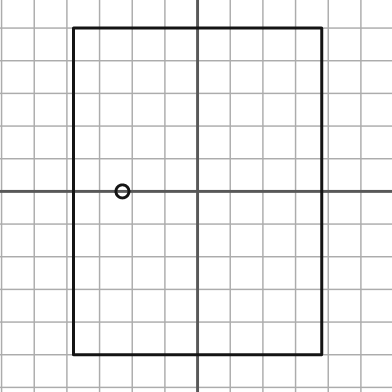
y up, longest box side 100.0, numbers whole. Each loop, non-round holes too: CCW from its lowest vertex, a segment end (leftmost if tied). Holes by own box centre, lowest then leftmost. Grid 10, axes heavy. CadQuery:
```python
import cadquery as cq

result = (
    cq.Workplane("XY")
    .moveTo(-38.0, -50.0)
    .lineTo(38.0, -50.0)
    .lineTo(38.0, 50.0)
    .lineTo(-38.0, 50.0)
    .close()
    .moveTo(-23.0, 0.0)
    .circle(2.0)
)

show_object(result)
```